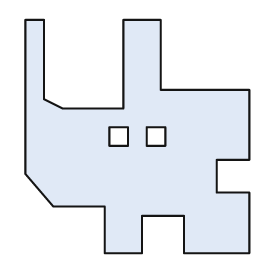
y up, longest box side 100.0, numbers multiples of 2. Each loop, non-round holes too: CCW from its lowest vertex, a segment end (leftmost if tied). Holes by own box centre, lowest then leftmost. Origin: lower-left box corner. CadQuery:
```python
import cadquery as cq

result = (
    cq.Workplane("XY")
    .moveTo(34.0, 0.0)
    .lineTo(50.0, 0.0)
    .lineTo(50.0, 16.0)
    .lineTo(68.0, 16.0)
    .lineTo(68.0, 0.0)
    .lineTo(96.0, 0.0)
    .lineTo(96.0, 26.0)
    .lineTo(82.0, 26.0)
    .lineTo(82.0, 40.0)
    .lineTo(96.0, 40.0)
    .lineTo(96.0, 70.0)
    .lineTo(58.0, 70.0)
    .lineTo(58.0, 100.0)
    .lineTo(42.0, 100.0)
    .lineTo(42.0, 62.0)
    .lineTo(16.0, 62.0)
    .lineTo(8.0, 66.0)
    .lineTo(8.0, 100.0)
    .lineTo(0.0, 100.0)
    .lineTo(0.0, 34.0)
    .lineTo(12.0, 20.0)
    .lineTo(34.0, 20.0)
    .close()
    .moveTo(36.0, 46.0)
    .lineTo(44.0, 46.0)
    .lineTo(44.0, 54.0)
    .lineTo(36.0, 54.0)
    .close()
    .moveTo(52.0, 46.0)
    .lineTo(60.0, 46.0)
    .lineTo(60.0, 54.0)
    .lineTo(52.0, 54.0)
    .close()
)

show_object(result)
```